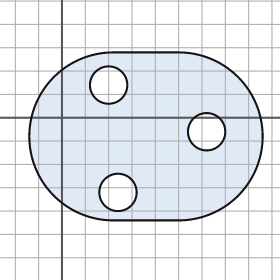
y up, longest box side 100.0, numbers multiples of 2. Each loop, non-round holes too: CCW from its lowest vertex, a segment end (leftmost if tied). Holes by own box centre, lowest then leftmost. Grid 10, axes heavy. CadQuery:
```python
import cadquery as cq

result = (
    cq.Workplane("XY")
    .moveTo(22.0, -44.0)
    .lineTo(50.0, -44.0)
    .threePointArc((86.0, -8.0), (50.0, 28.0))
    .lineTo(22.0, 28.0)
    .threePointArc((-14.0, -8.0), (22.0, -44.0))
    .close()
    .moveTo(24.0, -32.0)
    .circle(8.0)
    .moveTo(62.0, -6.0)
    .circle(8.0)
    .moveTo(20.0, 14.0)
    .circle(8.0)
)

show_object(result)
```